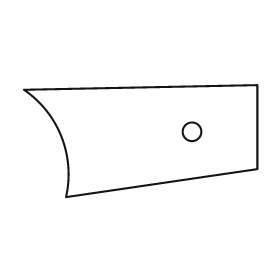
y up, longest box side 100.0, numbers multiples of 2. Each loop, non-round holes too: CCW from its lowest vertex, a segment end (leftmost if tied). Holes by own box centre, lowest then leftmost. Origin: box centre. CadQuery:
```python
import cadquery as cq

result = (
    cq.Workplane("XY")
    .moveTo(-32.0, -24.0)
    .lineTo(50.0, -12.0)
    .lineTo(50.0, 24.0)
    .lineTo(-50.0, 22.0)
    .threePointArc((-34.0, 2.0), (-32.0, -24.0))
    .close()
    .moveTo(22.0, 4.0)
    .circle(4.0)
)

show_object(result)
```